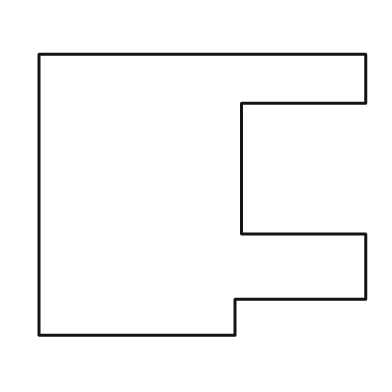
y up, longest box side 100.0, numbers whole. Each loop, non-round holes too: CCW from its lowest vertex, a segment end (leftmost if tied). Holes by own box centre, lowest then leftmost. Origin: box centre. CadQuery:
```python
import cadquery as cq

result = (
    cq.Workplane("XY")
    .moveTo(-50.0, -43.0)
    .lineTo(10.0, -43.0)
    .lineTo(10.0, -32.0)
    .lineTo(50.0, -32.0)
    .lineTo(50.0, -12.0)
    .lineTo(12.0, -12.0)
    .lineTo(12.0, 28.0)
    .lineTo(50.0, 28.0)
    .lineTo(50.0, 43.0)
    .lineTo(-50.0, 43.0)
    .close()
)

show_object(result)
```